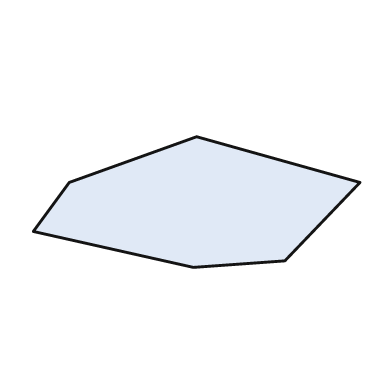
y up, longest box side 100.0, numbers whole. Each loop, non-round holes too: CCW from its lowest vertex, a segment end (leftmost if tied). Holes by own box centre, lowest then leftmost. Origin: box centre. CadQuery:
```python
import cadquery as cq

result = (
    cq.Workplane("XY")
    .moveTo(-1.0, -20.0)
    .lineTo(27.0, -18.0)
    .lineTo(50.0, 6.0)
    .lineTo(0.0, 20.0)
    .lineTo(-39.0, 6.0)
    .lineTo(-50.0, -9.0)
    .close()
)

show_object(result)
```